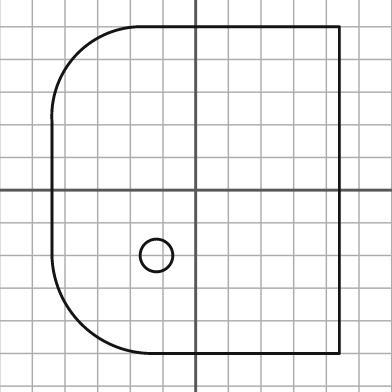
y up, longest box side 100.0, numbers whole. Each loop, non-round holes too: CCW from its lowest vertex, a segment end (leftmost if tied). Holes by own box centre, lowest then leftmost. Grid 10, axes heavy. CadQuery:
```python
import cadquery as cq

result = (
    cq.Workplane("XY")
    .moveTo(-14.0, -50.0)
    .lineTo(44.0, -50.0)
    .lineTo(44.0, 50.0)
    .lineTo(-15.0, 50.0)
    .threePointArc((-36.0, 42.0), (-44.0, 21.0))
    .lineTo(-44.0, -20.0)
    .threePointArc((-35.0, -41.0), (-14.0, -50.0))
    .close()
    .moveTo(-12.0, -20.0)
    .circle(5.0)
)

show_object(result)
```